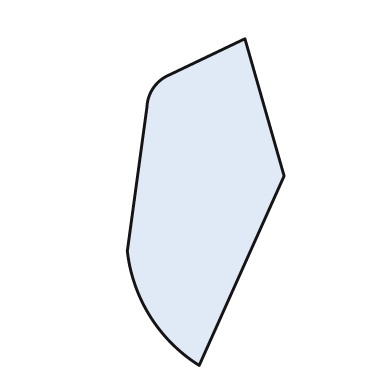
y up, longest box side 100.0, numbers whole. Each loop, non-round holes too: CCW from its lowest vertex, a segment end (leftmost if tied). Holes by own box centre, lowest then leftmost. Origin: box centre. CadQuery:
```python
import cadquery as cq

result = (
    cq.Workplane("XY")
    .moveTo(-2.0, -50.0)
    .lineTo(24.0, 8.0)
    .lineTo(12.0, 50.0)
    .lineTo(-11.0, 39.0)
    .threePointArc((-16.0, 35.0), (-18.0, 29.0))
    .lineTo(-24.0, -15.0)
    .threePointArc((-17.0, -35.0), (-2.0, -50.0))
    .close()
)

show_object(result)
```